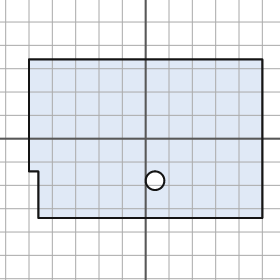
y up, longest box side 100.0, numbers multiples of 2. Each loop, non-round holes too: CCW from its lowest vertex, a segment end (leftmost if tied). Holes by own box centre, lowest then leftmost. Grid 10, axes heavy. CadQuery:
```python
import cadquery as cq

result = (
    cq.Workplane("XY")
    .moveTo(-46.0, -34.0)
    .lineTo(50.0, -34.0)
    .lineTo(50.0, 34.0)
    .lineTo(-50.0, 34.0)
    .lineTo(-50.0, -14.0)
    .lineTo(-46.0, -14.0)
    .close()
    .moveTo(4.0, -18.0)
    .circle(4.0)
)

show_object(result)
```